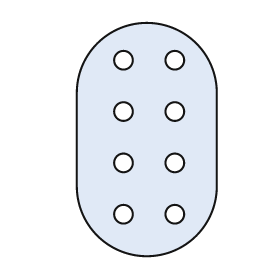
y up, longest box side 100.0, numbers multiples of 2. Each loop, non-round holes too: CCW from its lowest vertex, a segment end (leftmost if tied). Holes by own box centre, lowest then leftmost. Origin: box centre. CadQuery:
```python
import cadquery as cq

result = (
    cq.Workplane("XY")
    .moveTo(-30.0, -20.0)
    .threePointArc((0.0, -50.0), (30.0, -20.0))
    .lineTo(30.0, 20.0)
    .threePointArc((0.0, 50.0), (-30.0, 20.0))
    .close()
    .moveTo(-10.0, -32.0)
    .circle(4.0)
    .moveTo(12.0, -32.0)
    .circle(4.0)
    .moveTo(-10.0, -10.0)
    .circle(4.0)
    .moveTo(12.0, -10.0)
    .circle(4.0)
    .moveTo(-10.0, 12.0)
    .circle(4.0)
    .moveTo(12.0, 12.0)
    .circle(4.0)
    .moveTo(-10.0, 34.0)
    .circle(4.0)
    .moveTo(12.0, 34.0)
    .circle(4.0)
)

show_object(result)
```